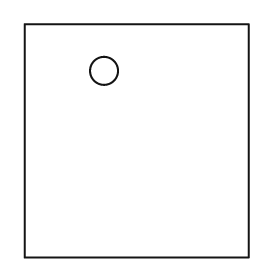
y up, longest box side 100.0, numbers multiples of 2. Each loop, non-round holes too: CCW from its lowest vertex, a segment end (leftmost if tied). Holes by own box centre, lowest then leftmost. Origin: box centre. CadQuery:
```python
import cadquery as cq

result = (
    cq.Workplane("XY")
    .moveTo(-48.0, -50.0)
    .lineTo(48.0, -50.0)
    .lineTo(48.0, 50.0)
    .lineTo(-48.0, 50.0)
    .close()
    .moveTo(-14.0, 30.0)
    .circle(6.0)
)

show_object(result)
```